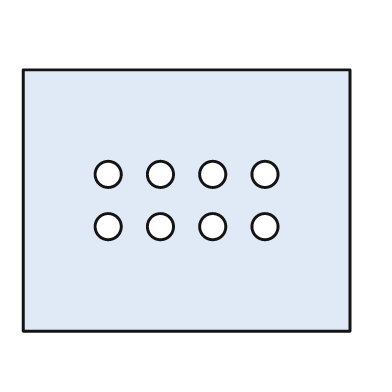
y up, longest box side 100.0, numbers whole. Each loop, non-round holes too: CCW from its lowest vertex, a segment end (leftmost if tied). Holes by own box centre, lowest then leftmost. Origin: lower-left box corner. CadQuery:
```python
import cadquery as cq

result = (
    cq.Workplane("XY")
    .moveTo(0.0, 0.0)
    .lineTo(100.0, 0.0)
    .lineTo(100.0, 80.0)
    .lineTo(0.0, 80.0)
    .close()
    .moveTo(26.0, 32.0)
    .circle(4.0)
    .moveTo(42.0, 32.0)
    .circle(4.0)
    .moveTo(58.0, 32.0)
    .circle(4.0)
    .moveTo(74.0, 32.0)
    .circle(4.0)
    .moveTo(26.0, 48.0)
    .circle(4.0)
    .moveTo(42.0, 48.0)
    .circle(4.0)
    .moveTo(58.0, 48.0)
    .circle(4.0)
    .moveTo(74.0, 48.0)
    .circle(4.0)
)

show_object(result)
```